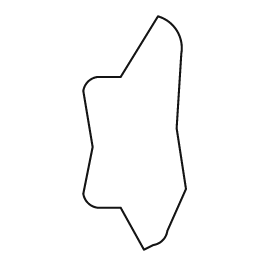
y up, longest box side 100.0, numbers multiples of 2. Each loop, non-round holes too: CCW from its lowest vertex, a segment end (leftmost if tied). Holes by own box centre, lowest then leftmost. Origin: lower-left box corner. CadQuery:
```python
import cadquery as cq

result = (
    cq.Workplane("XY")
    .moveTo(26.0, 0.0)
    .lineTo(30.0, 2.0)
    .threePointArc((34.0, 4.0), (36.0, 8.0))
    .lineTo(44.0, 26.0)
    .lineTo(40.0, 52.0)
    .lineTo(42.0, 84.0)
    .threePointArc((40.0, 94.0), (32.0, 100.0))
    .lineTo(16.0, 74.0)
    .lineTo(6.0, 74.0)
    .threePointArc((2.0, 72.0), (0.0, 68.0))
    .lineTo(4.0, 44.0)
    .lineTo(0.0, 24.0)
    .threePointArc((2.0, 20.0), (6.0, 18.0))
    .lineTo(16.0, 18.0)
    .close()
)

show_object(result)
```